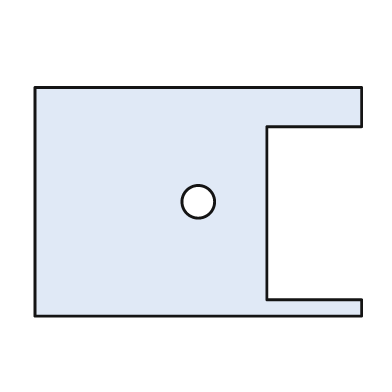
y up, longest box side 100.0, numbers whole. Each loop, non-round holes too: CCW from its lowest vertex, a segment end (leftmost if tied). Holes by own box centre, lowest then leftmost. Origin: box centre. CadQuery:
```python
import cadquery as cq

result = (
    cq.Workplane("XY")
    .moveTo(-50.0, -35.0)
    .lineTo(50.0, -35.0)
    .lineTo(50.0, -30.0)
    .lineTo(21.0, -30.0)
    .lineTo(21.0, 23.0)
    .lineTo(50.0, 23.0)
    .lineTo(50.0, 35.0)
    .lineTo(-50.0, 35.0)
    .close()
    .moveTo(0.0, 0.0)
    .circle(5.0)
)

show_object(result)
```